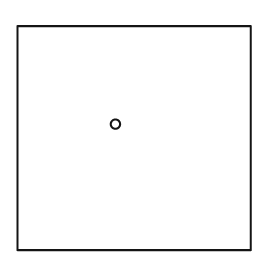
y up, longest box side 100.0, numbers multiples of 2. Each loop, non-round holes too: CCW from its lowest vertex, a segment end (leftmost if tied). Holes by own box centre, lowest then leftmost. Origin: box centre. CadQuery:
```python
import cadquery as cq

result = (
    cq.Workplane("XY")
    .moveTo(-50.0, -48.0)
    .lineTo(50.0, -48.0)
    .lineTo(50.0, 48.0)
    .lineTo(-50.0, 48.0)
    .close()
    .moveTo(-8.0, 6.0)
    .circle(2.0)
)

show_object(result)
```